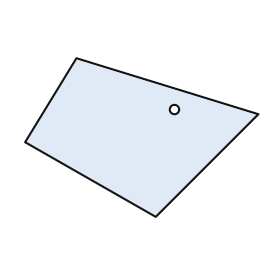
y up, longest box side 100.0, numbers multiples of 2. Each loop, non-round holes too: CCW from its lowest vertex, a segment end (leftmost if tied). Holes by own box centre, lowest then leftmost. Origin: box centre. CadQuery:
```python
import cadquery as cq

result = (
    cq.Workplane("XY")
    .moveTo(6.0, -34.0)
    .lineTo(50.0, 10.0)
    .lineTo(-28.0, 34.0)
    .lineTo(-50.0, -2.0)
    .close()
    .moveTo(14.0, 12.0)
    .circle(2.0)
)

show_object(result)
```